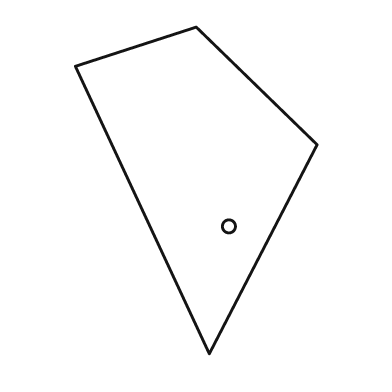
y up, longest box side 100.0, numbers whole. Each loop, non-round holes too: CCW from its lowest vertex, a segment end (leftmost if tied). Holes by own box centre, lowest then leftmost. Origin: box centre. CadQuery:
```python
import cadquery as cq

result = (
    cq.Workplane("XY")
    .moveTo(4.0, -50.0)
    .lineTo(37.0, 14.0)
    .lineTo(0.0, 50.0)
    .lineTo(-37.0, 38.0)
    .close()
    .moveTo(10.0, -11.0)
    .circle(2.0)
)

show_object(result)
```